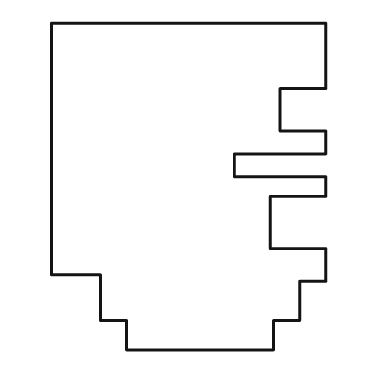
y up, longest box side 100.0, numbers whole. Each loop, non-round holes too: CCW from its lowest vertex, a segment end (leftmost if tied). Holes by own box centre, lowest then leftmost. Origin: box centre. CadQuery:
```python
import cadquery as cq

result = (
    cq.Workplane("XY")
    .moveTo(-19.0, -50.0)
    .lineTo(26.0, -50.0)
    .lineTo(26.0, -41.0)
    .lineTo(34.0, -41.0)
    .lineTo(34.0, -29.0)
    .lineTo(42.0, -29.0)
    .lineTo(42.0, -19.0)
    .lineTo(25.0, -19.0)
    .lineTo(25.0, -3.0)
    .lineTo(42.0, -3.0)
    .lineTo(42.0, 3.0)
    .lineTo(14.0, 3.0)
    .lineTo(14.0, 10.0)
    .lineTo(42.0, 10.0)
    .lineTo(42.0, 17.0)
    .lineTo(28.0, 17.0)
    .lineTo(28.0, 30.0)
    .lineTo(42.0, 30.0)
    .lineTo(42.0, 50.0)
    .lineTo(-42.0, 50.0)
    .lineTo(-42.0, -27.0)
    .lineTo(-27.0, -27.0)
    .lineTo(-27.0, -41.0)
    .lineTo(-19.0, -41.0)
    .close()
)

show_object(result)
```